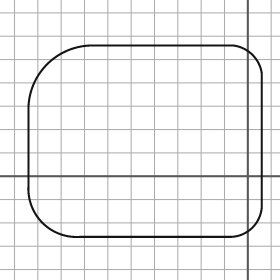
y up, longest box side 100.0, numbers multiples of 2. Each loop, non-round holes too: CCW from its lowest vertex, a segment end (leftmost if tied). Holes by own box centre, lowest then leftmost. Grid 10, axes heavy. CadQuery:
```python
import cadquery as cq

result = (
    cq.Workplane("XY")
    .moveTo(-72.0, -26.0)
    .lineTo(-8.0, -26.0)
    .threePointArc((2.0, -22.0), (6.0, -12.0))
    .lineTo(6.0, 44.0)
    .threePointArc((2.0, 52.0), (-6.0, 56.0))
    .lineTo(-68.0, 56.0)
    .threePointArc((-86.0, 48.0), (-94.0, 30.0))
    .lineTo(-94.0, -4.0)
    .threePointArc((-88.0, -20.0), (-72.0, -26.0))
    .close()
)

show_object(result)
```